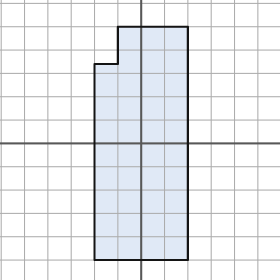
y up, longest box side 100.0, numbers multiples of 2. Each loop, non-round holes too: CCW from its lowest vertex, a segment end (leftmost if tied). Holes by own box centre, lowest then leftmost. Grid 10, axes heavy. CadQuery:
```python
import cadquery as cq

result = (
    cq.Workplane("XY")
    .moveTo(-20.0, -50.0)
    .lineTo(20.0, -50.0)
    .lineTo(20.0, 50.0)
    .lineTo(-10.0, 50.0)
    .lineTo(-10.0, 34.0)
    .lineTo(-20.0, 34.0)
    .close()
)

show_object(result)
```